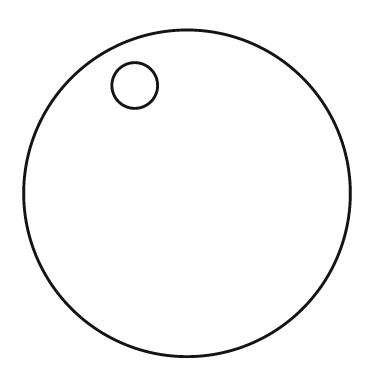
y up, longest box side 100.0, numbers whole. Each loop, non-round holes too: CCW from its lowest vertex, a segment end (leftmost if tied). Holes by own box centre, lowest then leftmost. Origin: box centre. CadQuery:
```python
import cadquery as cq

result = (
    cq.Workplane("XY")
    .moveTo(0.0, 0.0)
    .circle(50.0)
    .moveTo(-16.0, 33.0)
    .circle(7.0)
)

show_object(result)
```